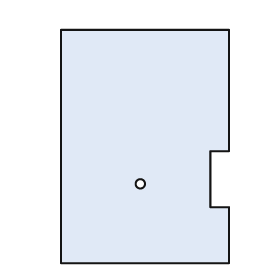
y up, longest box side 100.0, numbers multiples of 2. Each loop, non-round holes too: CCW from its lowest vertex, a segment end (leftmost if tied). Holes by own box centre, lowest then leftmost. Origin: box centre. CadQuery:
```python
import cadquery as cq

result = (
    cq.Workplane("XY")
    .moveTo(-36.0, -50.0)
    .lineTo(36.0, -50.0)
    .lineTo(36.0, -26.0)
    .lineTo(28.0, -26.0)
    .lineTo(28.0, -2.0)
    .lineTo(36.0, -2.0)
    .lineTo(36.0, 50.0)
    .lineTo(-36.0, 50.0)
    .close()
    .moveTo(-2.0, -16.0)
    .circle(2.0)
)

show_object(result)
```